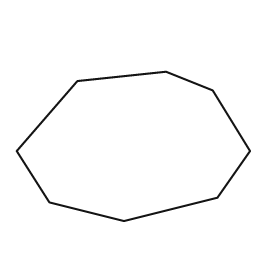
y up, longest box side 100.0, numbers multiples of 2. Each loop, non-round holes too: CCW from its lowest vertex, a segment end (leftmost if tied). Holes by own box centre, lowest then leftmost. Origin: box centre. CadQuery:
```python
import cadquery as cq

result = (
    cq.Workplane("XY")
    .moveTo(-4.0, -32.0)
    .lineTo(36.0, -22.0)
    .lineTo(50.0, -2.0)
    .lineTo(34.0, 24.0)
    .lineTo(14.0, 32.0)
    .lineTo(-24.0, 28.0)
    .lineTo(-50.0, -2.0)
    .lineTo(-36.0, -24.0)
    .close()
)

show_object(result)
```